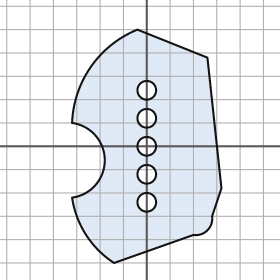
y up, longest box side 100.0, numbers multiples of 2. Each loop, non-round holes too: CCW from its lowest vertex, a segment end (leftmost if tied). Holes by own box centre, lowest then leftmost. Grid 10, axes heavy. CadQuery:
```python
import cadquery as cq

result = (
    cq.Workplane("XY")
    .moveTo(-14.0, -50.0)
    .lineTo(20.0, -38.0)
    .threePointArc((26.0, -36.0), (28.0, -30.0))
    .lineTo(32.0, -18.0)
    .lineTo(26.0, 38.0)
    .lineTo(-4.0, 50.0)
    .threePointArc((-24.0, 34.0), (-32.0, 10.0))
    .threePointArc((-18.0, -6.0), (-32.0, -22.0))
    .threePointArc((-26.0, -38.0), (-14.0, -50.0))
    .close()
    .moveTo(0.0, -24.0)
    .circle(4.0)
    .moveTo(0.0, -12.0)
    .circle(4.0)
    .moveTo(0.0, 0.0)
    .circle(4.0)
    .moveTo(0.0, 12.0)
    .circle(4.0)
    .moveTo(0.0, 24.0)
    .circle(4.0)
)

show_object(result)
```